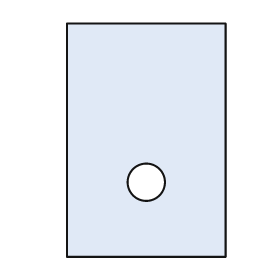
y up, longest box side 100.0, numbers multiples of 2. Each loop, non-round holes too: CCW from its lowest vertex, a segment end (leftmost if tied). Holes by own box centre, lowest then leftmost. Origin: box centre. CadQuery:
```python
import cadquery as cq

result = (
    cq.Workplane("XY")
    .moveTo(-34.0, -50.0)
    .lineTo(34.0, -50.0)
    .lineTo(34.0, 50.0)
    .lineTo(-34.0, 50.0)
    .close()
    .moveTo(0.0, -18.0)
    .circle(8.0)
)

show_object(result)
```